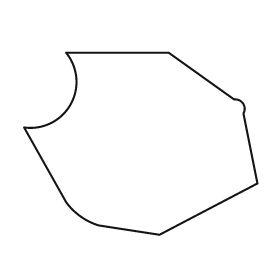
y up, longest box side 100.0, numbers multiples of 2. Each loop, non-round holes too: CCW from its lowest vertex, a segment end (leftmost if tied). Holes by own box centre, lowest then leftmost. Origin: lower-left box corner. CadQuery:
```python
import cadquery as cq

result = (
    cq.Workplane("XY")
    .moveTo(58.0, 0.0)
    .lineTo(100.0, 22.0)
    .lineTo(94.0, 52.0)
    .threePointArc((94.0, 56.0), (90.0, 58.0))
    .lineTo(62.0, 78.0)
    .lineTo(18.0, 78.0)
    .threePointArc((20.0, 56.0), (0.0, 46.0))
    .lineTo(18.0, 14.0)
    .threePointArc((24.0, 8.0), (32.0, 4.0))
    .close()
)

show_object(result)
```